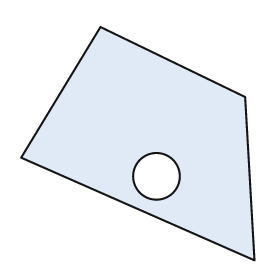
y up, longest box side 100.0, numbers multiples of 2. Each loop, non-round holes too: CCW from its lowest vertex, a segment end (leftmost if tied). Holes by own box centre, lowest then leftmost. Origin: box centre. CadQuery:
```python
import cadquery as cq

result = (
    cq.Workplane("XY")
    .moveTo(50.0, -50.0)
    .lineTo(46.0, 20.0)
    .lineTo(-16.0, 50.0)
    .lineTo(-50.0, -6.0)
    .close()
    .moveTo(8.0, -14.0)
    .circle(10.0)
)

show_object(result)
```